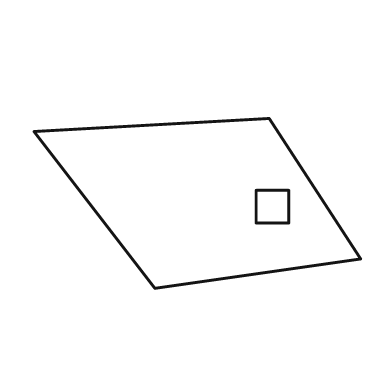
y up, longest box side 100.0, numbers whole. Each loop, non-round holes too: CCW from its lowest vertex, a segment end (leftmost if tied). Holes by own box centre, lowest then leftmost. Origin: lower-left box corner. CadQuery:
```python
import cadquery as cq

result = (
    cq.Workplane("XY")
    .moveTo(37.0, 0.0)
    .lineTo(100.0, 9.0)
    .lineTo(72.0, 52.0)
    .lineTo(0.0, 48.0)
    .close()
    .moveTo(68.0, 20.0)
    .lineTo(78.0, 20.0)
    .lineTo(78.0, 30.0)
    .lineTo(68.0, 30.0)
    .close()
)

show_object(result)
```